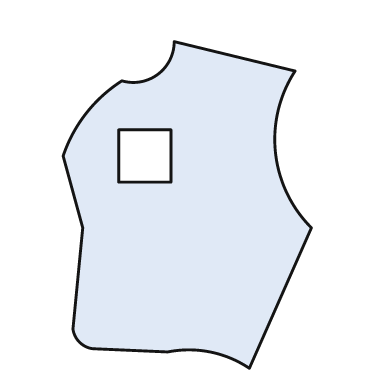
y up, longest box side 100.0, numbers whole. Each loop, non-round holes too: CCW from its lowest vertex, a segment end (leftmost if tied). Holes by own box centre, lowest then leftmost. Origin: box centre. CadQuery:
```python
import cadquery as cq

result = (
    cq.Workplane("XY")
    .moveTo(19.0, -50.0)
    .lineTo(38.0, -7.0)
    .threePointArc((27.0, 16.0), (33.0, 41.0))
    .lineTo(-4.0, 50.0)
    .threePointArc((-9.0, 40.0), (-20.0, 38.0))
    .threePointArc((-31.0, 28.0), (-38.0, 15.0))
    .lineTo(-32.0, -7.0)
    .lineTo(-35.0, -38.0)
    .threePointArc((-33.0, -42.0), (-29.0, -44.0))
    .lineTo(-6.0, -45.0)
    .threePointArc((7.0, -45.0), (19.0, -50.0))
    .close()
    .moveTo(-21.0, 7.0)
    .lineTo(-5.0, 7.0)
    .lineTo(-5.0, 23.0)
    .lineTo(-21.0, 23.0)
    .close()
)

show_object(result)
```